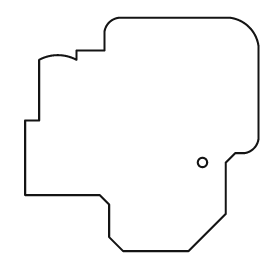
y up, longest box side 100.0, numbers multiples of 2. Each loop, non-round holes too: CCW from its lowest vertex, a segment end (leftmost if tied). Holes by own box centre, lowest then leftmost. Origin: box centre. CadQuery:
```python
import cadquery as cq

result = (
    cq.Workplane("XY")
    .moveTo(-8.0, -50.0)
    .lineTo(20.0, -50.0)
    .lineTo(36.0, -34.0)
    .lineTo(36.0, -12.0)
    .lineTo(40.0, -8.0)
    .lineTo(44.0, -8.0)
    .threePointArc((48.0, -6.0), (50.0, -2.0))
    .lineTo(50.0, 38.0)
    .threePointArc((46.0, 46.0), (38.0, 50.0))
    .lineTo(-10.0, 50.0)
    .threePointArc((-14.0, 48.0), (-16.0, 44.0))
    .lineTo(-16.0, 36.0)
    .lineTo(-28.0, 36.0)
    .lineTo(-28.0, 32.0)
    .threePointArc((-36.0, 34.0), (-44.0, 32.0))
    .lineTo(-44.0, 6.0)
    .lineTo(-50.0, 6.0)
    .lineTo(-50.0, -26.0)
    .lineTo(-18.0, -26.0)
    .lineTo(-14.0, -30.0)
    .lineTo(-14.0, -44.0)
    .close()
    .moveTo(26.0, -12.0)
    .circle(2.0)
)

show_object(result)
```